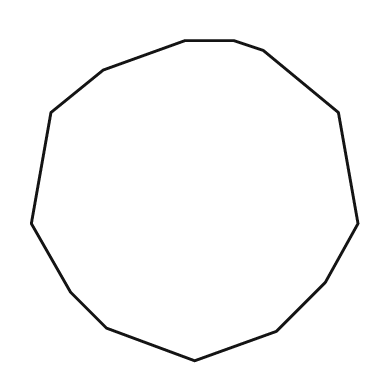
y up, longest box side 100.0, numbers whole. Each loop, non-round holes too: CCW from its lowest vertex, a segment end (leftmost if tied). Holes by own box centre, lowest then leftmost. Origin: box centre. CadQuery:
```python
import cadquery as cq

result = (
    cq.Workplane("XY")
    .moveTo(0.0, -49.0)
    .lineTo(25.0, -40.0)
    .lineTo(40.0, -25.0)
    .lineTo(50.0, -7.0)
    .lineTo(44.0, 27.0)
    .lineTo(21.0, 46.0)
    .lineTo(12.0, 49.0)
    .lineTo(-3.0, 49.0)
    .lineTo(-28.0, 40.0)
    .lineTo(-44.0, 27.0)
    .lineTo(-50.0, -7.0)
    .lineTo(-38.0, -28.0)
    .lineTo(-27.0, -39.0)
    .close()
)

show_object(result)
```